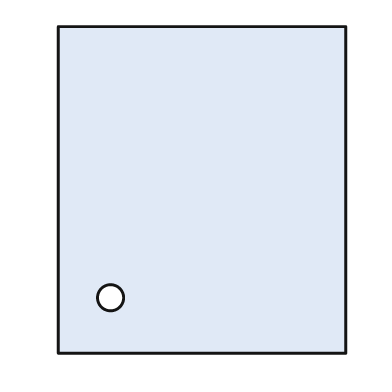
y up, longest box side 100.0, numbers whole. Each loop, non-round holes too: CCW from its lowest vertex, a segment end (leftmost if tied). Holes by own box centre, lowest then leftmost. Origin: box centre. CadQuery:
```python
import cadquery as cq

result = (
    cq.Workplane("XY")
    .moveTo(-44.0, -50.0)
    .lineTo(44.0, -50.0)
    .lineTo(44.0, 50.0)
    .lineTo(-44.0, 50.0)
    .close()
    .moveTo(-28.0, -33.0)
    .circle(4.0)
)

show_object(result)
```